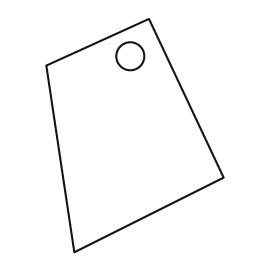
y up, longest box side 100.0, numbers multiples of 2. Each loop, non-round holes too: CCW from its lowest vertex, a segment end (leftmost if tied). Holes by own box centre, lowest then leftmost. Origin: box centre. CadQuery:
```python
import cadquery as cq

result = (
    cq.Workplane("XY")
    .moveTo(-26.0, -50.0)
    .lineTo(38.0, -18.0)
    .lineTo(6.0, 50.0)
    .lineTo(-38.0, 30.0)
    .close()
    .moveTo(-2.0, 34.0)
    .circle(6.0)
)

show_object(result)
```